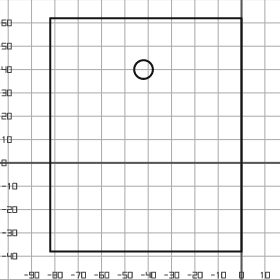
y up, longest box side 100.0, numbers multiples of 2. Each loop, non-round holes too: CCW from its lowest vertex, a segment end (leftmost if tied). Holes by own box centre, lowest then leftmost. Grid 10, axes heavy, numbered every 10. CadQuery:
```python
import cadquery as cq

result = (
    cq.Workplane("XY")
    .moveTo(-82.0, -38.0)
    .lineTo(0.0, -38.0)
    .lineTo(0.0, 62.0)
    .lineTo(-82.0, 62.0)
    .close()
    .moveTo(-42.0, 40.0)
    .circle(4.0)
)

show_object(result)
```